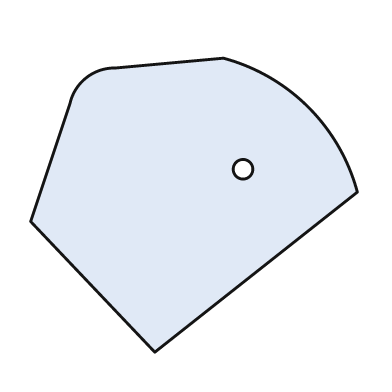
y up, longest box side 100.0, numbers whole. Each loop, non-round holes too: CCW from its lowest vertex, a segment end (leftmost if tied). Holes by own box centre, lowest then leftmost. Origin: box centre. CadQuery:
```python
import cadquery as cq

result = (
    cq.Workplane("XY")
    .moveTo(-12.0, -45.0)
    .lineTo(50.0, 4.0)
    .threePointArc((35.0, 30.0), (9.0, 45.0))
    .lineTo(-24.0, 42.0)
    .threePointArc((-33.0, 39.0), (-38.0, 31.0))
    .lineTo(-50.0, -5.0)
    .close()
    .moveTo(15.0, 11.0)
    .circle(3.0)
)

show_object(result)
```